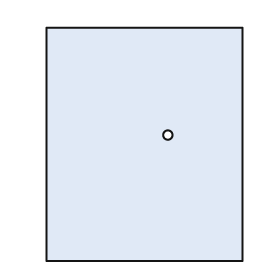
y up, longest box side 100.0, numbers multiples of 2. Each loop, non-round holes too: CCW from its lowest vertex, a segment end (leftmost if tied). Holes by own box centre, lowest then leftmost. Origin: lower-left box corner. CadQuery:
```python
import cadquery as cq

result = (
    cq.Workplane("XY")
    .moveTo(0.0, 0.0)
    .lineTo(84.0, 0.0)
    .lineTo(84.0, 100.0)
    .lineTo(0.0, 100.0)
    .close()
    .moveTo(52.0, 54.0)
    .circle(2.0)
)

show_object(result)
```